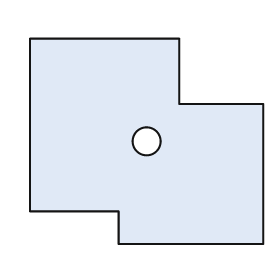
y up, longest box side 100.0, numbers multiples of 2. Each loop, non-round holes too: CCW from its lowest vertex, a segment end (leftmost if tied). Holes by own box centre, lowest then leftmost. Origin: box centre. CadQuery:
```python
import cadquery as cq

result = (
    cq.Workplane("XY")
    .moveTo(-12.0, -44.0)
    .lineTo(50.0, -44.0)
    .lineTo(50.0, 16.0)
    .lineTo(14.0, 16.0)
    .lineTo(14.0, 44.0)
    .lineTo(-50.0, 44.0)
    .lineTo(-50.0, -30.0)
    .lineTo(-12.0, -30.0)
    .close()
    .moveTo(0.0, 0.0)
    .circle(6.0)
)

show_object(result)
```